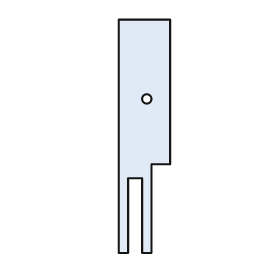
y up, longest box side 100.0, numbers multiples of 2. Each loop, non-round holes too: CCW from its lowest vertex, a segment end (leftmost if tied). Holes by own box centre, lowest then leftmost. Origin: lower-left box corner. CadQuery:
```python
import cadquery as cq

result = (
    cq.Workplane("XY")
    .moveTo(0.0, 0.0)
    .lineTo(4.0, 0.0)
    .lineTo(4.0, 32.0)
    .lineTo(10.0, 32.0)
    .lineTo(10.0, 0.0)
    .lineTo(14.0, 0.0)
    .lineTo(14.0, 38.0)
    .lineTo(22.0, 38.0)
    .lineTo(22.0, 100.0)
    .lineTo(0.0, 100.0)
    .close()
    .moveTo(12.0, 66.0)
    .circle(2.0)
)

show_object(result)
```